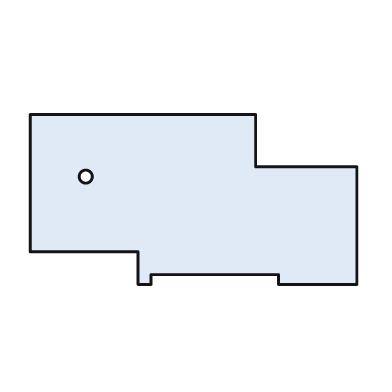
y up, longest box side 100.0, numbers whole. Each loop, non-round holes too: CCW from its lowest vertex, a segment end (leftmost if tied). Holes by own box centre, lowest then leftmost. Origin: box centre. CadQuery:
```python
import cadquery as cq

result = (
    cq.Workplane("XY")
    .moveTo(-17.0, -26.0)
    .lineTo(-13.0, -26.0)
    .lineTo(-13.0, -23.0)
    .lineTo(26.0, -23.0)
    .lineTo(26.0, -26.0)
    .lineTo(50.0, -26.0)
    .lineTo(50.0, 10.0)
    .lineTo(19.0, 10.0)
    .lineTo(19.0, 26.0)
    .lineTo(-50.0, 26.0)
    .lineTo(-50.0, -16.0)
    .lineTo(-17.0, -16.0)
    .close()
    .moveTo(-33.0, 7.0)
    .circle(2.0)
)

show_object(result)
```